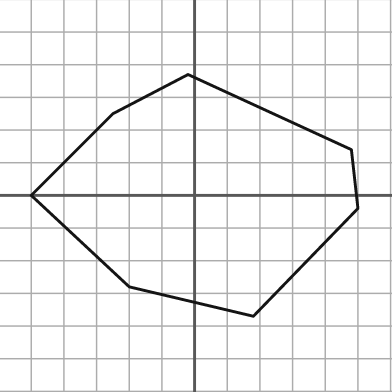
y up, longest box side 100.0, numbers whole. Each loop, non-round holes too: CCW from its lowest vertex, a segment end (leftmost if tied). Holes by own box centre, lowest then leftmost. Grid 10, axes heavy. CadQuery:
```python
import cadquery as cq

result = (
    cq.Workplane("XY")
    .moveTo(18.0, -37.0)
    .lineTo(50.0, -4.0)
    .lineTo(48.0, 14.0)
    .lineTo(-2.0, 37.0)
    .lineTo(-25.0, 25.0)
    .lineTo(-50.0, 0.0)
    .lineTo(-20.0, -28.0)
    .close()
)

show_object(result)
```